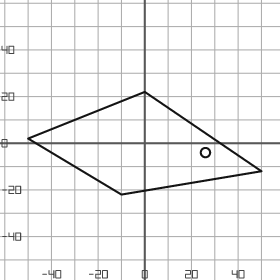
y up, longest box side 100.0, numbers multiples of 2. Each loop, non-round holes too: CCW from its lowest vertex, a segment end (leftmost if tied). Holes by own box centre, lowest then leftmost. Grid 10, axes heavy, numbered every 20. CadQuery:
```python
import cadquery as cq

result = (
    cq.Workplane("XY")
    .moveTo(-10.0, -22.0)
    .lineTo(50.0, -12.0)
    .lineTo(0.0, 22.0)
    .lineTo(-50.0, 2.0)
    .close()
    .moveTo(26.0, -4.0)
    .circle(2.0)
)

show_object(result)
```